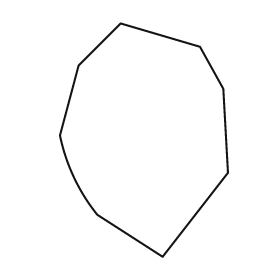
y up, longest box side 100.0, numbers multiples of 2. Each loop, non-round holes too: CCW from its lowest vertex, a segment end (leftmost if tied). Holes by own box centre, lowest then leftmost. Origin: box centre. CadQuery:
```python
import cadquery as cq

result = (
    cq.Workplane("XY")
    .moveTo(8.0, -50.0)
    .lineTo(36.0, -14.0)
    .lineTo(34.0, 22.0)
    .lineTo(24.0, 40.0)
    .lineTo(-10.0, 50.0)
    .lineTo(-28.0, 32.0)
    .lineTo(-36.0, 2.0)
    .threePointArc((-30.0, -16.0), (-20.0, -32.0))
    .close()
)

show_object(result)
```